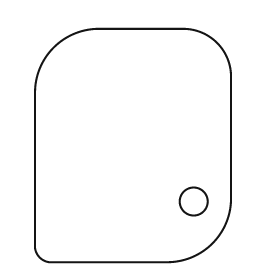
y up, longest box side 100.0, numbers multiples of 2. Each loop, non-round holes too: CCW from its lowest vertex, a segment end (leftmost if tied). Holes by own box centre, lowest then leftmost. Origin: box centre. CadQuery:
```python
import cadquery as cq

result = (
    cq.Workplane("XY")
    .moveTo(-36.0, -50.0)
    .lineTo(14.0, -50.0)
    .threePointArc((34.0, -42.0), (42.0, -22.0))
    .lineTo(42.0, 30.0)
    .threePointArc((36.0, 44.0), (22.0, 50.0))
    .lineTo(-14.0, 50.0)
    .threePointArc((-34.0, 42.0), (-42.0, 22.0))
    .lineTo(-42.0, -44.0)
    .threePointArc((-40.0, -48.0), (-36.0, -50.0))
    .close()
    .moveTo(26.0, -24.0)
    .circle(6.0)
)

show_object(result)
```